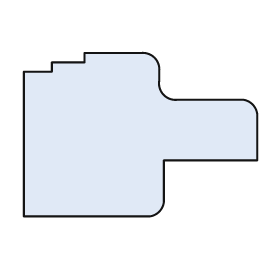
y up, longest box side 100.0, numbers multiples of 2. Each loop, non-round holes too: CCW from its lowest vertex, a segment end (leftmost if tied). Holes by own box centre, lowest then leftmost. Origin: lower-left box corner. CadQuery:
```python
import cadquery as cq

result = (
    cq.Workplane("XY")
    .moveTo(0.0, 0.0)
    .lineTo(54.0, 0.0)
    .threePointArc((58.0, 2.0), (60.0, 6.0))
    .lineTo(60.0, 24.0)
    .lineTo(100.0, 24.0)
    .lineTo(100.0, 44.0)
    .threePointArc((98.0, 48.0), (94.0, 50.0))
    .lineTo(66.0, 50.0)
    .threePointArc((60.0, 52.0), (58.0, 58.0))
    .lineTo(58.0, 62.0)
    .threePointArc((56.0, 68.0), (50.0, 70.0))
    .lineTo(26.0, 70.0)
    .lineTo(26.0, 66.0)
    .lineTo(12.0, 66.0)
    .lineTo(12.0, 62.0)
    .lineTo(0.0, 62.0)
    .close()
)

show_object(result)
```